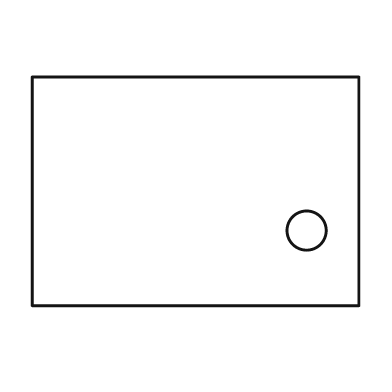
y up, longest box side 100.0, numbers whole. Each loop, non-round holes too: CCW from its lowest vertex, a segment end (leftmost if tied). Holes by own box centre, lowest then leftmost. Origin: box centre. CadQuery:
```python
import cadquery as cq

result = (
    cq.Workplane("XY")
    .moveTo(-50.0, -35.0)
    .lineTo(50.0, -35.0)
    .lineTo(50.0, 35.0)
    .lineTo(-50.0, 35.0)
    .close()
    .moveTo(34.0, -12.0)
    .circle(6.0)
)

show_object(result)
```